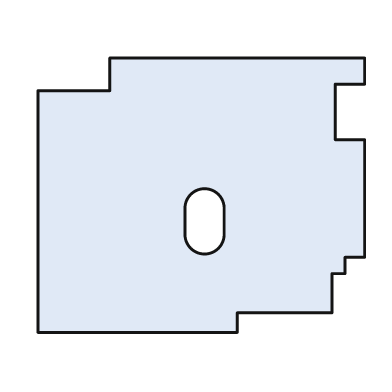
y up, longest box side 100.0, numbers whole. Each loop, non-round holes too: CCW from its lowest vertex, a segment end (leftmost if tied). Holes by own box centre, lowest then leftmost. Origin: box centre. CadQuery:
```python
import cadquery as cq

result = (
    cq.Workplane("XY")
    .moveTo(-50.0, -42.0)
    .lineTo(11.0, -42.0)
    .lineTo(11.0, -36.0)
    .lineTo(40.0, -36.0)
    .lineTo(40.0, -24.0)
    .lineTo(44.0, -24.0)
    .lineTo(44.0, -19.0)
    .lineTo(50.0, -19.0)
    .lineTo(50.0, 17.0)
    .lineTo(41.0, 17.0)
    .lineTo(41.0, 34.0)
    .lineTo(50.0, 34.0)
    .lineTo(50.0, 42.0)
    .lineTo(-28.0, 42.0)
    .lineTo(-28.0, 32.0)
    .lineTo(-50.0, 32.0)
    .close()
    .moveTo(-5.0, -12.0)
    .threePointArc((1.0, -18.0), (7.0, -12.0))
    .lineTo(7.0, -4.0)
    .threePointArc((1.0, 2.0), (-5.0, -4.0))
    .close()
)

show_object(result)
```